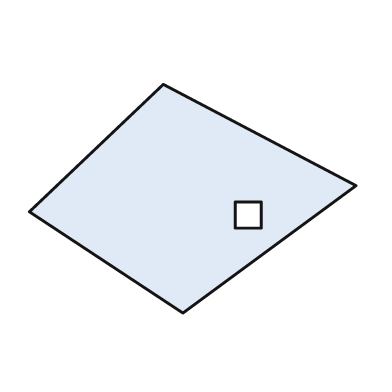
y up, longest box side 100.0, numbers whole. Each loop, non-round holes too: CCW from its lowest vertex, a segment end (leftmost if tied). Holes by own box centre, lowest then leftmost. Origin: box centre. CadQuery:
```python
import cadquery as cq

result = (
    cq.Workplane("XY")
    .moveTo(-3.0, -35.0)
    .lineTo(50.0, 4.0)
    .lineTo(-9.0, 35.0)
    .lineTo(-50.0, -4.0)
    .close()
    .moveTo(13.0, -9.0)
    .lineTo(21.0, -9.0)
    .lineTo(21.0, -1.0)
    .lineTo(13.0, -1.0)
    .close()
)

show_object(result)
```